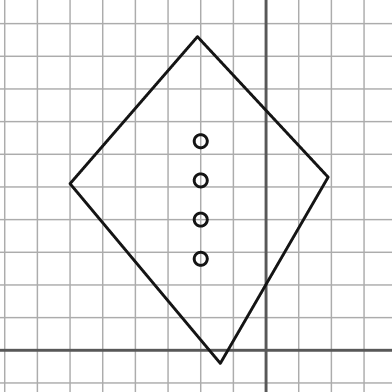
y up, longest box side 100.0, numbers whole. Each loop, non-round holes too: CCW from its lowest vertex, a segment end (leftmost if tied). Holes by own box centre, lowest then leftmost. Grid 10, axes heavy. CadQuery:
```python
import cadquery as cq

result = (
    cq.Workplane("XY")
    .moveTo(-14.0, -4.0)
    .lineTo(19.0, 53.0)
    .lineTo(-21.0, 96.0)
    .lineTo(-60.0, 51.0)
    .close()
    .moveTo(-20.0, 28.0)
    .circle(2.0)
    .moveTo(-20.0, 40.0)
    .circle(2.0)
    .moveTo(-20.0, 52.0)
    .circle(2.0)
    .moveTo(-20.0, 64.0)
    .circle(2.0)
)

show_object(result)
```